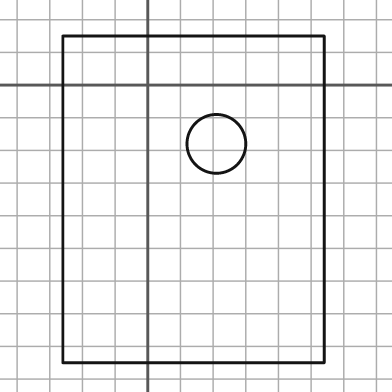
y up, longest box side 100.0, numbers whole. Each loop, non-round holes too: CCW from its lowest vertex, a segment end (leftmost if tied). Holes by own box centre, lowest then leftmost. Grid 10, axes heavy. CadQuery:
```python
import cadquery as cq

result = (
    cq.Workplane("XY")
    .moveTo(-26.0, -85.0)
    .lineTo(54.0, -85.0)
    .lineTo(54.0, 15.0)
    .lineTo(-26.0, 15.0)
    .close()
    .moveTo(21.0, -18.0)
    .circle(9.0)
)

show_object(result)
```